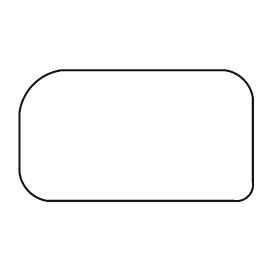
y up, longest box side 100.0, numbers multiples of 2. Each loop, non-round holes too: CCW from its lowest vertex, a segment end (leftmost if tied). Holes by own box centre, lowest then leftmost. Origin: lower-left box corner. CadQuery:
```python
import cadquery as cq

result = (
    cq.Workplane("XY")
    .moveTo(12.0, 0.0)
    .lineTo(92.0, 0.0)
    .threePointArc((98.0, 2.0), (100.0, 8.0))
    .lineTo(100.0, 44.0)
    .threePointArc((96.0, 52.0), (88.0, 56.0))
    .lineTo(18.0, 56.0)
    .threePointArc((6.0, 50.0), (0.0, 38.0))
    .lineTo(0.0, 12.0)
    .threePointArc((4.0, 4.0), (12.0, 0.0))
    .close()
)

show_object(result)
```